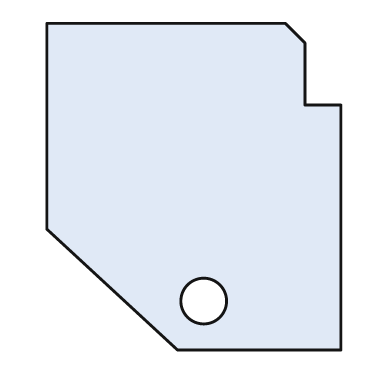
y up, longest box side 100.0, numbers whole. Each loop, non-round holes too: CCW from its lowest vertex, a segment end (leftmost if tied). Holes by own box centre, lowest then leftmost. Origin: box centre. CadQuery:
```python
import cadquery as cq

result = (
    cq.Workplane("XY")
    .moveTo(-5.0, -50.0)
    .lineTo(45.0, -50.0)
    .lineTo(45.0, 25.0)
    .lineTo(34.0, 25.0)
    .lineTo(34.0, 44.0)
    .lineTo(28.0, 50.0)
    .lineTo(-45.0, 50.0)
    .lineTo(-45.0, -13.0)
    .close()
    .moveTo(3.0, -35.0)
    .circle(7.0)
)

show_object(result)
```